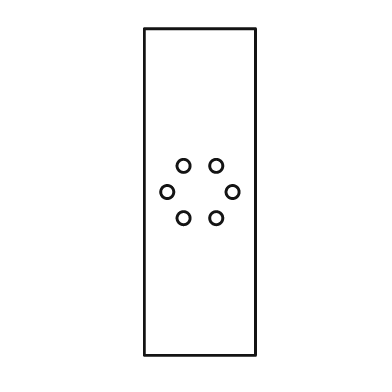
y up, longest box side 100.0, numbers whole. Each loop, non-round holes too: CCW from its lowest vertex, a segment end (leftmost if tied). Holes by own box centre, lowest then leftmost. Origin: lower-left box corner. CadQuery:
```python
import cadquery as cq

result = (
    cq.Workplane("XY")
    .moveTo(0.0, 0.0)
    .lineTo(34.0, 0.0)
    .lineTo(34.0, 100.0)
    .lineTo(0.0, 100.0)
    .close()
    .moveTo(12.0, 42.0)
    .circle(2.0)
    .moveTo(22.0, 42.0)
    .circle(2.0)
    .moveTo(7.0, 50.0)
    .circle(2.0)
    .moveTo(27.0, 50.0)
    .circle(2.0)
    .moveTo(12.0, 58.0)
    .circle(2.0)
    .moveTo(22.0, 58.0)
    .circle(2.0)
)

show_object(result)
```